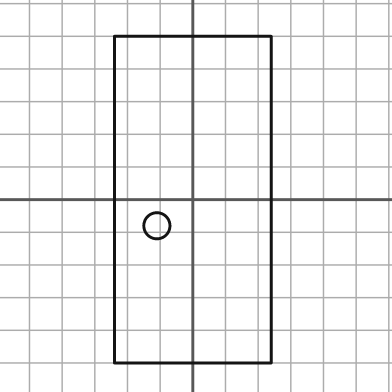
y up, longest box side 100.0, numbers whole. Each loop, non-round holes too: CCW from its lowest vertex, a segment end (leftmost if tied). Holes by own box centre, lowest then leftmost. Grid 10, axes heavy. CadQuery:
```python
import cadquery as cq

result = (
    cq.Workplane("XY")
    .moveTo(-24.0, -50.0)
    .lineTo(24.0, -50.0)
    .lineTo(24.0, 50.0)
    .lineTo(-24.0, 50.0)
    .close()
    .moveTo(-11.0, -8.0)
    .circle(4.0)
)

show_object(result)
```